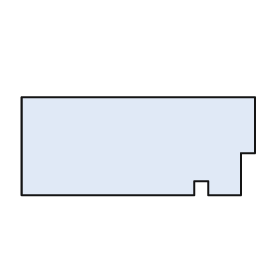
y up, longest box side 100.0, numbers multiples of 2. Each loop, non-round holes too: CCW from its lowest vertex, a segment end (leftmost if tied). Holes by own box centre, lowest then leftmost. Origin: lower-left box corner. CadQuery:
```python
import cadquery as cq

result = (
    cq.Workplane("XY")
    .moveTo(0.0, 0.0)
    .lineTo(74.0, 0.0)
    .lineTo(74.0, 6.0)
    .lineTo(80.0, 6.0)
    .lineTo(80.0, 0.0)
    .lineTo(94.0, 0.0)
    .lineTo(94.0, 18.0)
    .lineTo(100.0, 18.0)
    .lineTo(100.0, 42.0)
    .lineTo(0.0, 42.0)
    .close()
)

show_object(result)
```